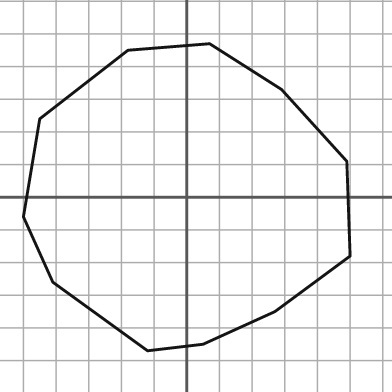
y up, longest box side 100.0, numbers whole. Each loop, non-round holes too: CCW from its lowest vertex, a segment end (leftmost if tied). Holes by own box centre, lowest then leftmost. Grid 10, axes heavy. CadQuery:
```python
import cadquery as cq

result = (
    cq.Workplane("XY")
    .moveTo(-12.0, -47.0)
    .lineTo(5.0, -45.0)
    .lineTo(27.0, -35.0)
    .lineTo(50.0, -18.0)
    .lineTo(49.0, 11.0)
    .lineTo(29.0, 33.0)
    .lineTo(7.0, 47.0)
    .lineTo(-18.0, 45.0)
    .lineTo(-45.0, 24.0)
    .lineTo(-50.0, -6.0)
    .lineTo(-41.0, -26.0)
    .close()
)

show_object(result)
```